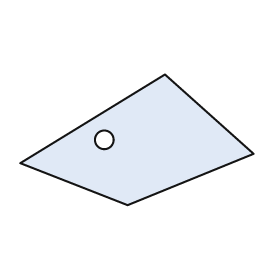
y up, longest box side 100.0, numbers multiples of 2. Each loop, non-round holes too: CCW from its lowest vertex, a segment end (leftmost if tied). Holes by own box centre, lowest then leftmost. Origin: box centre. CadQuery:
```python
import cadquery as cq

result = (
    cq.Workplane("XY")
    .moveTo(-4.0, -28.0)
    .lineTo(50.0, -6.0)
    .lineTo(12.0, 28.0)
    .lineTo(-50.0, -10.0)
    .close()
    .moveTo(-14.0, 0.0)
    .circle(4.0)
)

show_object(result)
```